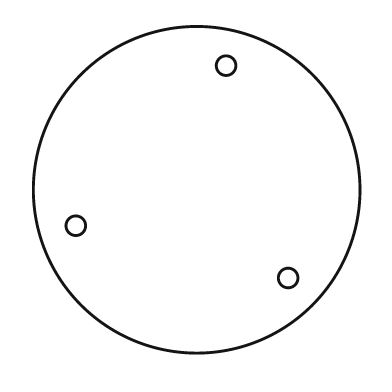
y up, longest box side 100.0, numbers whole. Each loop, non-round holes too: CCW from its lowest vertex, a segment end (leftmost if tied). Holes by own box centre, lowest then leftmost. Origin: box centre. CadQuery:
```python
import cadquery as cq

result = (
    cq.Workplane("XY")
    .moveTo(0.0, 0.0)
    .circle(50.0)
    .moveTo(28.0, -27.0)
    .circle(3.0)
    .moveTo(-37.0, -11.0)
    .circle(3.0)
    .moveTo(9.0, 38.0)
    .circle(3.0)
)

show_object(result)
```